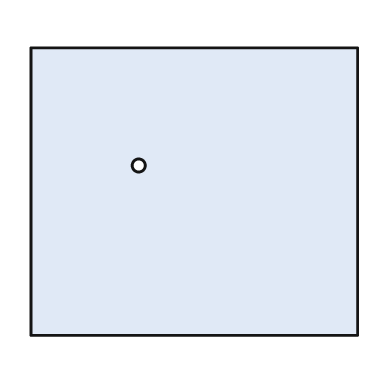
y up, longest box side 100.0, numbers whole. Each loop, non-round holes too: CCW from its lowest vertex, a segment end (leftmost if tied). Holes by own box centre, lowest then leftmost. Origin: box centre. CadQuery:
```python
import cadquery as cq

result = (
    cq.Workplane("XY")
    .moveTo(-50.0, -44.0)
    .lineTo(50.0, -44.0)
    .lineTo(50.0, 44.0)
    .lineTo(-50.0, 44.0)
    .close()
    .moveTo(-17.0, 8.0)
    .circle(2.0)
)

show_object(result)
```